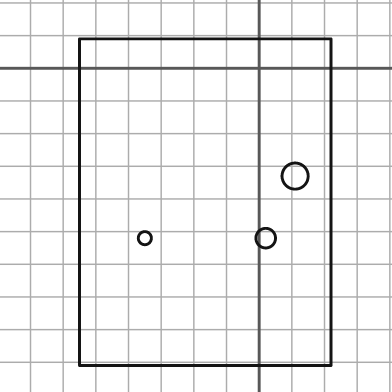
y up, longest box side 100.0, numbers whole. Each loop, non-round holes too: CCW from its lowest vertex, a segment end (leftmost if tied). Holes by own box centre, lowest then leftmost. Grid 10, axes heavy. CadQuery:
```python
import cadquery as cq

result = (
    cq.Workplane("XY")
    .moveTo(-55.0, -91.0)
    .lineTo(22.0, -91.0)
    .lineTo(22.0, 9.0)
    .lineTo(-55.0, 9.0)
    .close()
    .moveTo(-35.0, -52.0)
    .circle(2.0)
    .moveTo(2.0, -52.0)
    .circle(3.0)
    .moveTo(11.0, -33.0)
    .circle(4.0)
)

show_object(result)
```